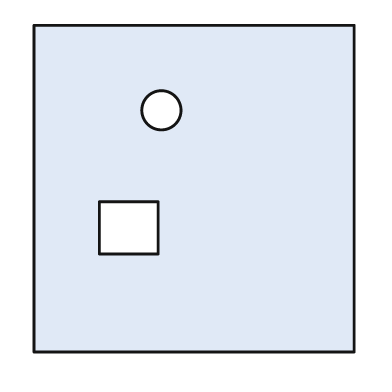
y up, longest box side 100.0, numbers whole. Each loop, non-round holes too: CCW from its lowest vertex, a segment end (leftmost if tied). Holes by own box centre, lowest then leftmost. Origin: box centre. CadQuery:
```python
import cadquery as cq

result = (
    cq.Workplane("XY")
    .moveTo(-49.0, -50.0)
    .lineTo(49.0, -50.0)
    .lineTo(49.0, 50.0)
    .lineTo(-49.0, 50.0)
    .close()
    .moveTo(-29.0, -20.0)
    .lineTo(-11.0, -20.0)
    .lineTo(-11.0, -4.0)
    .lineTo(-29.0, -4.0)
    .close()
    .moveTo(-10.0, 24.0)
    .circle(6.0)
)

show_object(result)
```